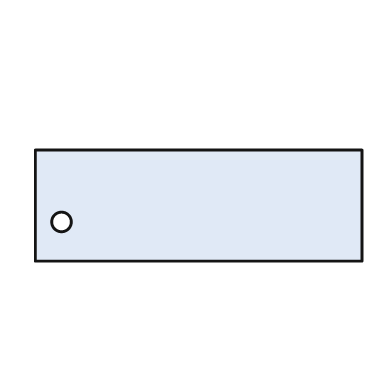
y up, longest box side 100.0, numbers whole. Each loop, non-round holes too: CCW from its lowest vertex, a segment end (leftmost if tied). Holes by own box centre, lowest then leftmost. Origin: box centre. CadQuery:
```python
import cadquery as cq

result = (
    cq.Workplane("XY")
    .moveTo(-50.0, -17.0)
    .lineTo(50.0, -17.0)
    .lineTo(50.0, 17.0)
    .lineTo(-50.0, 17.0)
    .close()
    .moveTo(-42.0, -5.0)
    .circle(3.0)
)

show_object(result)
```